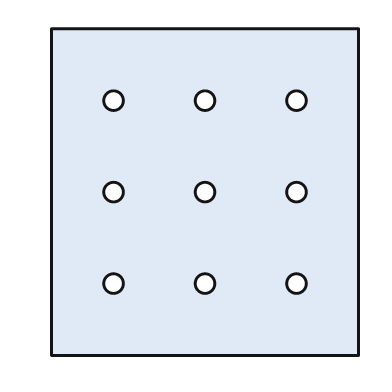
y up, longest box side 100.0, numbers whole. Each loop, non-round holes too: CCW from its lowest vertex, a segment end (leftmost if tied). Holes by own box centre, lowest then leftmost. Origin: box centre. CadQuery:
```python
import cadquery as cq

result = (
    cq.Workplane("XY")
    .moveTo(-47.0, -50.0)
    .lineTo(47.0, -50.0)
    .lineTo(47.0, 50.0)
    .lineTo(-47.0, 50.0)
    .close()
    .moveTo(-28.0, -28.0)
    .circle(3.0)
    .moveTo(0.0, -28.0)
    .circle(3.0)
    .moveTo(28.0, -28.0)
    .circle(3.0)
    .moveTo(-28.0, 0.0)
    .circle(3.0)
    .moveTo(0.0, 0.0)
    .circle(3.0)
    .moveTo(28.0, 0.0)
    .circle(3.0)
    .moveTo(-28.0, 28.0)
    .circle(3.0)
    .moveTo(0.0, 28.0)
    .circle(3.0)
    .moveTo(28.0, 28.0)
    .circle(3.0)
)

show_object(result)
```